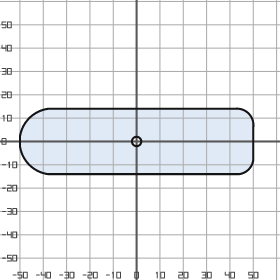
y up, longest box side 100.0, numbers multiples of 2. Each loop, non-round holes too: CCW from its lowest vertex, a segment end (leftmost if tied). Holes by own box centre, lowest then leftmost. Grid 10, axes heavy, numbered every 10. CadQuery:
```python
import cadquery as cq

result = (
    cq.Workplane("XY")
    .moveTo(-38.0, -14.0)
    .lineTo(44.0, -14.0)
    .threePointArc((48.0, -12.0), (50.0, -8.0))
    .lineTo(50.0, 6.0)
    .threePointArc((48.0, 12.0), (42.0, 14.0))
    .lineTo(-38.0, 14.0)
    .threePointArc((-46.0, 10.0), (-50.0, 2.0))
    .lineTo(-50.0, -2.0)
    .threePointArc((-46.0, -10.0), (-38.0, -14.0))
    .close()
    .moveTo(0.0, 0.0)
    .circle(2.0)
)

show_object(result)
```